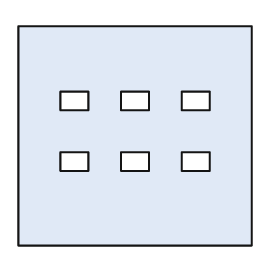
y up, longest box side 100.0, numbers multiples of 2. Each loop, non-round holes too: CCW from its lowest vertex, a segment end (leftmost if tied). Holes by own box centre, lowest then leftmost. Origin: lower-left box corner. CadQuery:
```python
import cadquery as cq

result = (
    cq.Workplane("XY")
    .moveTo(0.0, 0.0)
    .lineTo(100.0, 0.0)
    .lineTo(100.0, 94.0)
    .lineTo(0.0, 94.0)
    .close()
    .moveTo(18.0, 32.0)
    .lineTo(30.0, 32.0)
    .lineTo(30.0, 40.0)
    .lineTo(18.0, 40.0)
    .close()
    .moveTo(44.0, 32.0)
    .lineTo(56.0, 32.0)
    .lineTo(56.0, 40.0)
    .lineTo(44.0, 40.0)
    .close()
    .moveTo(70.0, 32.0)
    .lineTo(82.0, 32.0)
    .lineTo(82.0, 40.0)
    .lineTo(70.0, 40.0)
    .close()
    .moveTo(18.0, 58.0)
    .lineTo(30.0, 58.0)
    .lineTo(30.0, 66.0)
    .lineTo(18.0, 66.0)
    .close()
    .moveTo(44.0, 58.0)
    .lineTo(56.0, 58.0)
    .lineTo(56.0, 66.0)
    .lineTo(44.0, 66.0)
    .close()
    .moveTo(70.0, 58.0)
    .lineTo(82.0, 58.0)
    .lineTo(82.0, 66.0)
    .lineTo(70.0, 66.0)
    .close()
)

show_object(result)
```